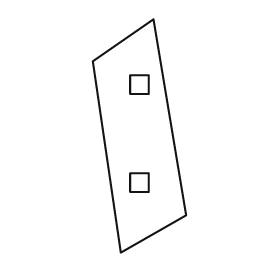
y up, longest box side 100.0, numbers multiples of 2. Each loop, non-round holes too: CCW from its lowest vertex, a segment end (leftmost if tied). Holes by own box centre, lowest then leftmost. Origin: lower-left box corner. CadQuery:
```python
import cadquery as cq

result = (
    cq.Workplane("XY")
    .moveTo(12.0, 0.0)
    .lineTo(40.0, 16.0)
    .lineTo(26.0, 100.0)
    .lineTo(0.0, 82.0)
    .close()
    .moveTo(16.0, 26.0)
    .lineTo(24.0, 26.0)
    .lineTo(24.0, 34.0)
    .lineTo(16.0, 34.0)
    .close()
    .moveTo(16.0, 68.0)
    .lineTo(24.0, 68.0)
    .lineTo(24.0, 76.0)
    .lineTo(16.0, 76.0)
    .close()
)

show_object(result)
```